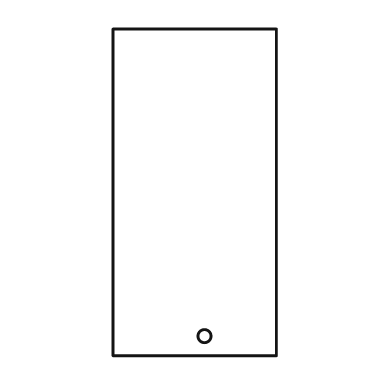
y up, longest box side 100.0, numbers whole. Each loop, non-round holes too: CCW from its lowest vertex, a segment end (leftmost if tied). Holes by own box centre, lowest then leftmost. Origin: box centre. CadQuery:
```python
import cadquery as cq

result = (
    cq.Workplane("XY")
    .moveTo(-25.0, -50.0)
    .lineTo(25.0, -50.0)
    .lineTo(25.0, 50.0)
    .lineTo(-25.0, 50.0)
    .close()
    .moveTo(3.0, -44.0)
    .circle(2.0)
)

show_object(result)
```